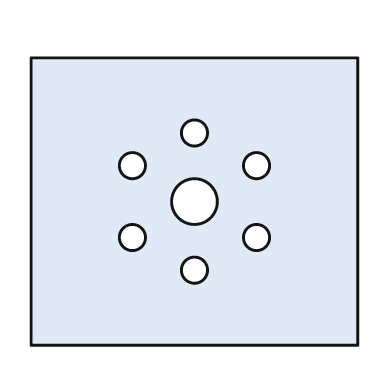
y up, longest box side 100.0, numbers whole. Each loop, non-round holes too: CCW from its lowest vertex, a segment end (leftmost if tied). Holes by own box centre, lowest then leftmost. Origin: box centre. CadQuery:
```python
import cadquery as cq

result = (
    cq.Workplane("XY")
    .moveTo(-50.0, -44.0)
    .lineTo(50.0, -44.0)
    .lineTo(50.0, 44.0)
    .lineTo(-50.0, 44.0)
    .close()
    .moveTo(0.0, -21.0)
    .circle(4.0)
    .moveTo(-19.0, -11.0)
    .circle(4.0)
    .moveTo(19.0, -11.0)
    .circle(4.0)
    .moveTo(0.0, 0.0)
    .circle(7.0)
    .moveTo(-19.0, 11.0)
    .circle(4.0)
    .moveTo(19.0, 11.0)
    .circle(4.0)
    .moveTo(0.0, 21.0)
    .circle(4.0)
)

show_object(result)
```